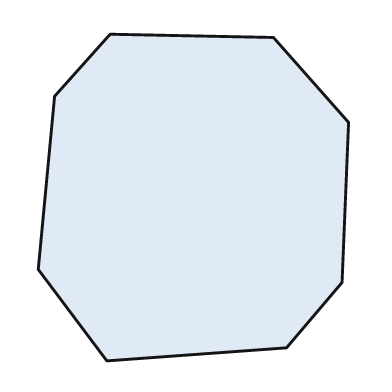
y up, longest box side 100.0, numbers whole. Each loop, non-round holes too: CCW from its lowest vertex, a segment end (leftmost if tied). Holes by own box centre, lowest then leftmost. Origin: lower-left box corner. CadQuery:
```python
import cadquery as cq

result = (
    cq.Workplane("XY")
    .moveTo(21.0, 0.0)
    .lineTo(76.0, 4.0)
    .lineTo(93.0, 24.0)
    .lineTo(95.0, 73.0)
    .lineTo(72.0, 99.0)
    .lineTo(22.0, 100.0)
    .lineTo(5.0, 81.0)
    .lineTo(0.0, 28.0)
    .close()
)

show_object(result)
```